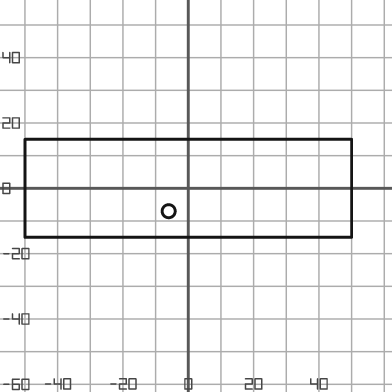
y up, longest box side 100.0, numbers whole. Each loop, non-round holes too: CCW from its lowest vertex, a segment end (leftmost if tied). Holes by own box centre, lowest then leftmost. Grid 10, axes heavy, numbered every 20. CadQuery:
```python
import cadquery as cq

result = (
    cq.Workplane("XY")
    .moveTo(-50.0, -15.0)
    .lineTo(50.0, -15.0)
    .lineTo(50.0, 15.0)
    .lineTo(-50.0, 15.0)
    .close()
    .moveTo(-6.0, -7.0)
    .circle(2.0)
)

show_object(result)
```